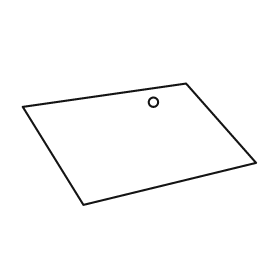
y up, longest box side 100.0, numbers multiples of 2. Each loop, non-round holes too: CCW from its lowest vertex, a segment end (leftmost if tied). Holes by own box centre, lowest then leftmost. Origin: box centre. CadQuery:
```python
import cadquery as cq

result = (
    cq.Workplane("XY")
    .moveTo(-24.0, -26.0)
    .lineTo(50.0, -8.0)
    .lineTo(20.0, 26.0)
    .lineTo(-50.0, 16.0)
    .close()
    .moveTo(6.0, 18.0)
    .circle(2.0)
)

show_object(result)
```